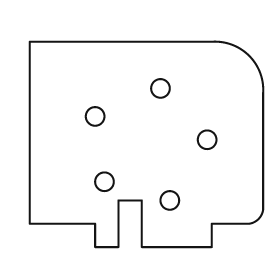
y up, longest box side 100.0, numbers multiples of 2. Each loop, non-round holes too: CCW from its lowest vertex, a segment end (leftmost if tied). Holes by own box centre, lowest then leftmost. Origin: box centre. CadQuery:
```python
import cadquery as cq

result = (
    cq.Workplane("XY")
    .moveTo(-22.0, -44.0)
    .lineTo(-12.0, -44.0)
    .lineTo(-12.0, -24.0)
    .lineTo(-2.0, -24.0)
    .lineTo(-2.0, -44.0)
    .lineTo(28.0, -44.0)
    .lineTo(28.0, -34.0)
    .lineTo(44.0, -34.0)
    .threePointArc((48.0, -32.0), (50.0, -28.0))
    .lineTo(50.0, 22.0)
    .threePointArc((44.0, 38.0), (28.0, 44.0))
    .lineTo(-50.0, 44.0)
    .lineTo(-50.0, -34.0)
    .lineTo(-22.0, -34.0)
    .close()
    .moveTo(10.0, -24.0)
    .circle(4.0)
    .moveTo(-18.0, -16.0)
    .circle(4.0)
    .moveTo(26.0, 2.0)
    .circle(4.0)
    .moveTo(-22.0, 12.0)
    .circle(4.0)
    .moveTo(6.0, 24.0)
    .circle(4.0)
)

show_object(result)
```